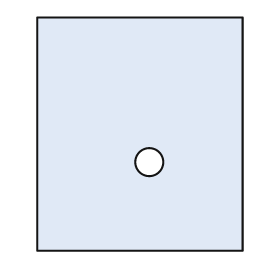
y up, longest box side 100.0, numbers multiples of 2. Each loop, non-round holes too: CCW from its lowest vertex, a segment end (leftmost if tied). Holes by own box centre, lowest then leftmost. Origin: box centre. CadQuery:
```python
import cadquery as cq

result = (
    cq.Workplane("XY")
    .moveTo(-44.0, -50.0)
    .lineTo(44.0, -50.0)
    .lineTo(44.0, 50.0)
    .lineTo(-44.0, 50.0)
    .close()
    .moveTo(4.0, -12.0)
    .circle(6.0)
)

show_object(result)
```